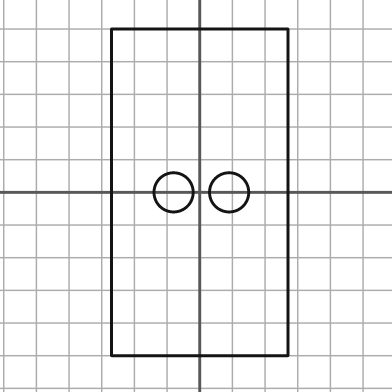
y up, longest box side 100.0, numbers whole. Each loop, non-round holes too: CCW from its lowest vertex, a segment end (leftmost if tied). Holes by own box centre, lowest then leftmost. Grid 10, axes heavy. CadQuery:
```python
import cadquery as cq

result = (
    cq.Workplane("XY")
    .moveTo(-27.0, -50.0)
    .lineTo(27.0, -50.0)
    .lineTo(27.0, 50.0)
    .lineTo(-27.0, 50.0)
    .close()
    .moveTo(-8.0, 0.0)
    .circle(6.0)
    .moveTo(9.0, 0.0)
    .circle(6.0)
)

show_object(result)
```